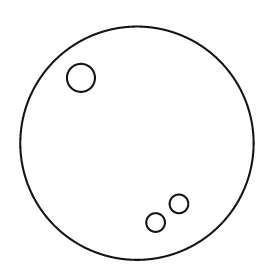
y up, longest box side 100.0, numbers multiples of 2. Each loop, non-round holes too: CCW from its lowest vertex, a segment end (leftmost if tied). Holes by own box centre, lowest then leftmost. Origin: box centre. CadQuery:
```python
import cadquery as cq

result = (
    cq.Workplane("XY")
    .moveTo(0.0, 0.0)
    .circle(50.0)
    .moveTo(8.0, -34.0)
    .circle(4.0)
    .moveTo(18.0, -26.0)
    .circle(4.0)
    .moveTo(-24.0, 28.0)
    .circle(6.0)
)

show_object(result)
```